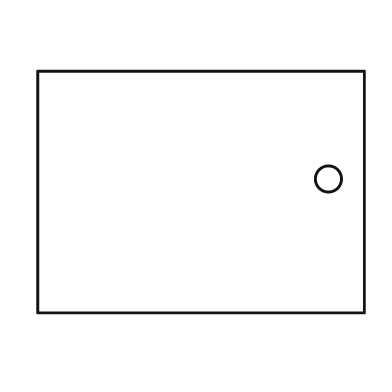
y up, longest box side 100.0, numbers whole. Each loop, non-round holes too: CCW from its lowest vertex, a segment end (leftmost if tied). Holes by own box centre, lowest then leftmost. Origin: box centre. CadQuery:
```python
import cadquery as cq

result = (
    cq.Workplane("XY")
    .moveTo(-50.0, -37.0)
    .lineTo(50.0, -37.0)
    .lineTo(50.0, 37.0)
    .lineTo(-50.0, 37.0)
    .close()
    .moveTo(39.0, 4.0)
    .circle(4.0)
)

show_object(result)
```